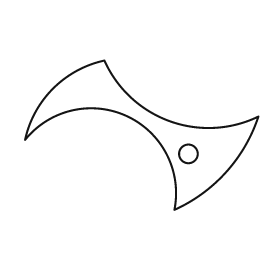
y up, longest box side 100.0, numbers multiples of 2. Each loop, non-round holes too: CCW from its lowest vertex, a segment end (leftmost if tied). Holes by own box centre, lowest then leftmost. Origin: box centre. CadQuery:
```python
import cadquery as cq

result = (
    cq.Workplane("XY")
    .moveTo(14.0, -32.0)
    .threePointArc((36.0, -16.0), (50.0, 8.0))
    .threePointArc((12.0, 6.0), (-16.0, 32.0))
    .threePointArc((-38.0, 20.0), (-50.0, -2.0))
    .threePointArc((-6.0, 8.0), (14.0, -32.0))
    .close()
    .moveTo(20.0, -8.0)
    .circle(4.0)
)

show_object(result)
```